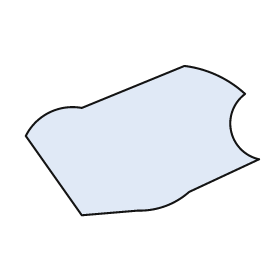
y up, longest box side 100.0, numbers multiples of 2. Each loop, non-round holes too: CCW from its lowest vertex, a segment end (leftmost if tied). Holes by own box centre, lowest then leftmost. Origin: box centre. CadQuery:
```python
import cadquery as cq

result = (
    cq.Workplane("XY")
    .moveTo(-26.0, -32.0)
    .lineTo(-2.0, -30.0)
    .threePointArc((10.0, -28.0), (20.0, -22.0))
    .lineTo(50.0, -8.0)
    .threePointArc((38.0, 4.0), (44.0, 20.0))
    .threePointArc((32.0, 28.0), (18.0, 32.0))
    .lineTo(-26.0, 14.0)
    .threePointArc((-40.0, 12.0), (-50.0, 2.0))
    .close()
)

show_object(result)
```